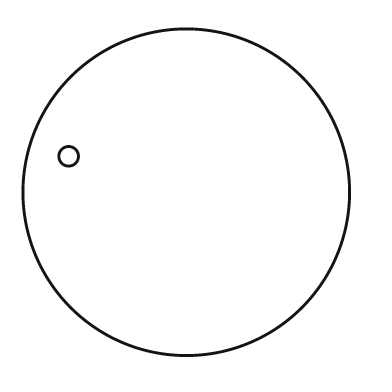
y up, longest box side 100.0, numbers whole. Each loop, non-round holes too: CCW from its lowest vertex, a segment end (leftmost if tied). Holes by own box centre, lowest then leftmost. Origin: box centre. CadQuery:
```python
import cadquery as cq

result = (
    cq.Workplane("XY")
    .moveTo(0.0, 0.0)
    .circle(50.0)
    .moveTo(-36.0, 11.0)
    .circle(3.0)
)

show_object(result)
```